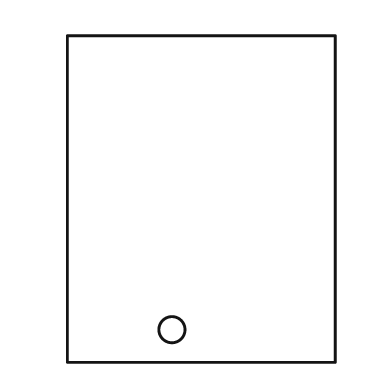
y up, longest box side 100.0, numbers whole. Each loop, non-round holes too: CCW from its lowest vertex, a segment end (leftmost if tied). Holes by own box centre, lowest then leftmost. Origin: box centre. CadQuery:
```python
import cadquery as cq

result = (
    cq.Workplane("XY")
    .moveTo(-41.0, -50.0)
    .lineTo(41.0, -50.0)
    .lineTo(41.0, 50.0)
    .lineTo(-41.0, 50.0)
    .close()
    .moveTo(-9.0, -40.0)
    .circle(4.0)
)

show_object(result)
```